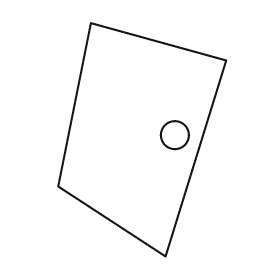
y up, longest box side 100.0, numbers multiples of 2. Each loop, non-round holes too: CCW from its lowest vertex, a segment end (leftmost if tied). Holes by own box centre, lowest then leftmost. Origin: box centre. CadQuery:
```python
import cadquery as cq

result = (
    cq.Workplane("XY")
    .moveTo(10.0, -50.0)
    .lineTo(36.0, 34.0)
    .lineTo(-22.0, 50.0)
    .lineTo(-36.0, -20.0)
    .close()
    .moveTo(14.0, 2.0)
    .circle(6.0)
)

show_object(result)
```